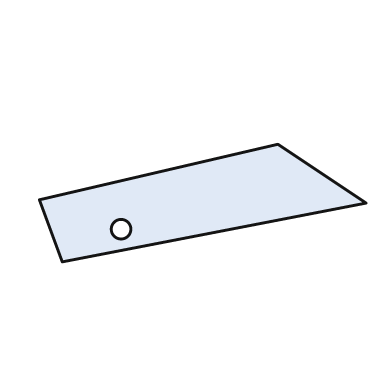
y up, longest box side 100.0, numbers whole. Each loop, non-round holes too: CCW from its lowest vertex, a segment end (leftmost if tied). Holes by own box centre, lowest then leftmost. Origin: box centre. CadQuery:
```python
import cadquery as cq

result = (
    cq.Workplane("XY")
    .moveTo(-43.0, -18.0)
    .lineTo(50.0, 0.0)
    .lineTo(23.0, 18.0)
    .lineTo(-50.0, 1.0)
    .close()
    .moveTo(-25.0, -8.0)
    .circle(3.0)
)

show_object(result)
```